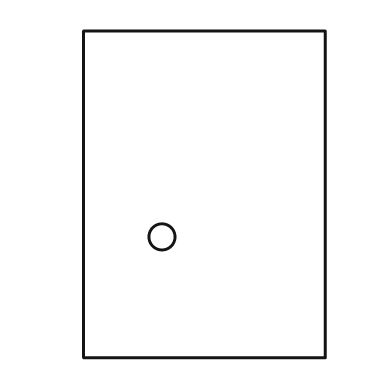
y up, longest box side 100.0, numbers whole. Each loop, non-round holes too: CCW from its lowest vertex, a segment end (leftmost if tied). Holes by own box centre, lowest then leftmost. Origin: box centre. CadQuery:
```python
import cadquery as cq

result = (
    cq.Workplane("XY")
    .moveTo(-37.0, -50.0)
    .lineTo(37.0, -50.0)
    .lineTo(37.0, 50.0)
    .lineTo(-37.0, 50.0)
    .close()
    .moveTo(-13.0, -13.0)
    .circle(4.0)
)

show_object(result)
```